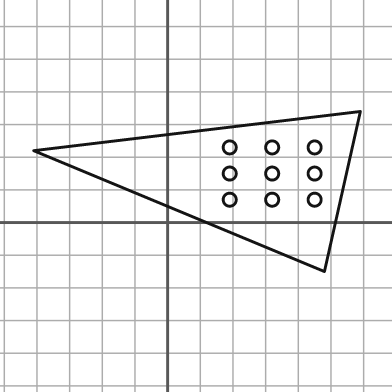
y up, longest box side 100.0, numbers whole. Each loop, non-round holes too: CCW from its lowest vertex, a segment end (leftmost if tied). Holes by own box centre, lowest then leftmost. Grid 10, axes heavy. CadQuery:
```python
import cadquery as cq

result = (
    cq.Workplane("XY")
    .moveTo(48.0, -15.0)
    .lineTo(59.0, 34.0)
    .lineTo(-41.0, 22.0)
    .close()
    .moveTo(19.0, 7.0)
    .circle(2.0)
    .moveTo(32.0, 7.0)
    .circle(2.0)
    .moveTo(45.0, 7.0)
    .circle(2.0)
    .moveTo(19.0, 15.0)
    .circle(2.0)
    .moveTo(32.0, 15.0)
    .circle(2.0)
    .moveTo(45.0, 15.0)
    .circle(2.0)
    .moveTo(19.0, 23.0)
    .circle(2.0)
    .moveTo(32.0, 23.0)
    .circle(2.0)
    .moveTo(45.0, 23.0)
    .circle(2.0)
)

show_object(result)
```